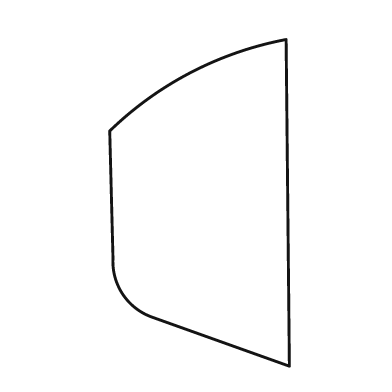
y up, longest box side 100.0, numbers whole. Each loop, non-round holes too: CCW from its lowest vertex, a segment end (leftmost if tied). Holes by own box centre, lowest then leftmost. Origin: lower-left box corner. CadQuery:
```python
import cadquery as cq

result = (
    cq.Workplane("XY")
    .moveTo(55.0, 0.0)
    .lineTo(54.0, 100.0)
    .threePointArc((25.0, 90.0), (0.0, 72.0))
    .lineTo(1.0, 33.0)
    .threePointArc((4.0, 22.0), (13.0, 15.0))
    .close()
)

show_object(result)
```